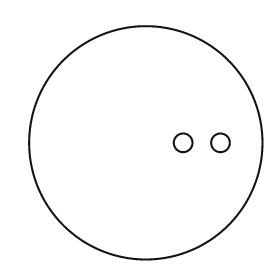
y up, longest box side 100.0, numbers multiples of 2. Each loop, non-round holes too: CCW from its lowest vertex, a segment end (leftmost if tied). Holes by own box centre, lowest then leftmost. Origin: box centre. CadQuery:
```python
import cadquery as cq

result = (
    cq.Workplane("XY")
    .moveTo(0.0, 0.0)
    .circle(50.0)
    .moveTo(16.0, 0.0)
    .circle(4.0)
    .moveTo(32.0, 0.0)
    .circle(4.0)
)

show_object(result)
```